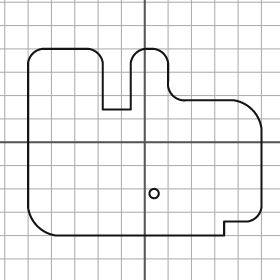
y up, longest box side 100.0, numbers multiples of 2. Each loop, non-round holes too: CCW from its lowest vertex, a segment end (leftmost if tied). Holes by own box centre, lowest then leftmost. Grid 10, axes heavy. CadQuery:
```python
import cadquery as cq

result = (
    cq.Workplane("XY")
    .moveTo(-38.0, -40.0)
    .lineTo(34.0, -40.0)
    .lineTo(34.0, -34.0)
    .lineTo(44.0, -34.0)
    .threePointArc((48.0, -32.0), (50.0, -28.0))
    .lineTo(50.0, 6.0)
    .threePointArc((46.0, 14.0), (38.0, 18.0))
    .lineTo(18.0, 18.0)
    .threePointArc((12.0, 20.0), (10.0, 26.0))
    .lineTo(10.0, 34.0)
    .threePointArc((8.0, 38.0), (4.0, 40.0))
    .lineTo(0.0, 40.0)
    .threePointArc((-4.0, 38.0), (-6.0, 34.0))
    .lineTo(-6.0, 14.0)
    .lineTo(-18.0, 14.0)
    .lineTo(-18.0, 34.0)
    .threePointArc((-20.0, 38.0), (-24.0, 40.0))
    .lineTo(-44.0, 40.0)
    .threePointArc((-48.0, 38.0), (-50.0, 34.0))
    .lineTo(-50.0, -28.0)
    .threePointArc((-46.0, -36.0), (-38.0, -40.0))
    .close()
    .moveTo(4.0, -22.0)
    .circle(2.0)
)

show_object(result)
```